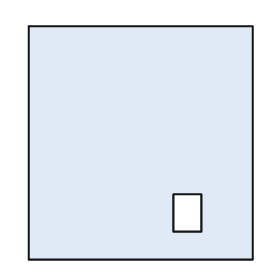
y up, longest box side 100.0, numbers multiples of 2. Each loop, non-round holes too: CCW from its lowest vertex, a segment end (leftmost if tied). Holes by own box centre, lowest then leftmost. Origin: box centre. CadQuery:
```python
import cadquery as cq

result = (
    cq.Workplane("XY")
    .moveTo(-48.0, -50.0)
    .lineTo(48.0, -50.0)
    .lineTo(48.0, 50.0)
    .lineTo(-48.0, 50.0)
    .close()
    .moveTo(14.0, -38.0)
    .lineTo(26.0, -38.0)
    .lineTo(26.0, -22.0)
    .lineTo(14.0, -22.0)
    .close()
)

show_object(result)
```